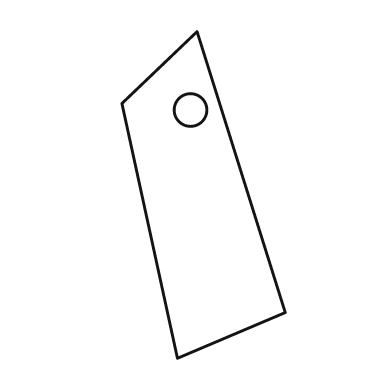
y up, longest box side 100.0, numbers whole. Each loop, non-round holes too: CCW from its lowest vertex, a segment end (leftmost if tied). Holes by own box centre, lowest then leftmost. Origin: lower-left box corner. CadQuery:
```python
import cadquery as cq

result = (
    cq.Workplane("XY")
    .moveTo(17.0, 0.0)
    .lineTo(50.0, 14.0)
    .lineTo(23.0, 100.0)
    .lineTo(0.0, 78.0)
    .close()
    .moveTo(21.0, 76.0)
    .circle(5.0)
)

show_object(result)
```